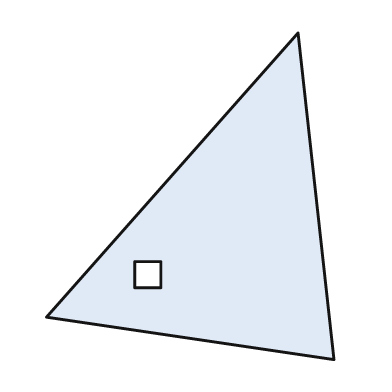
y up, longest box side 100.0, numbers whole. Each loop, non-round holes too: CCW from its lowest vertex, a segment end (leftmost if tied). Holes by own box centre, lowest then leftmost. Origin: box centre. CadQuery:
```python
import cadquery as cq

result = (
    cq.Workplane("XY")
    .moveTo(44.0, -50.0)
    .lineTo(33.0, 50.0)
    .lineTo(-44.0, -37.0)
    .close()
    .moveTo(-17.0, -28.0)
    .lineTo(-9.0, -28.0)
    .lineTo(-9.0, -20.0)
    .lineTo(-17.0, -20.0)
    .close()
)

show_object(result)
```